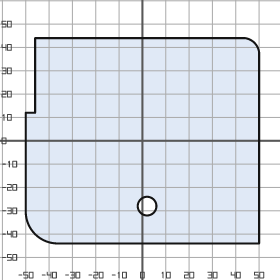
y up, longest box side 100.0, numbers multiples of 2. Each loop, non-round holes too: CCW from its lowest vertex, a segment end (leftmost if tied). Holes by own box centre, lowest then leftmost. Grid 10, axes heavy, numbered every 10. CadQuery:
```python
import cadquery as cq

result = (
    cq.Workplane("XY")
    .moveTo(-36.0, -44.0)
    .lineTo(50.0, -44.0)
    .lineTo(50.0, 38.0)
    .threePointArc((48.0, 42.0), (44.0, 44.0))
    .lineTo(-46.0, 44.0)
    .lineTo(-46.0, 12.0)
    .lineTo(-50.0, 12.0)
    .lineTo(-50.0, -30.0)
    .threePointArc((-46.0, -40.0), (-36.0, -44.0))
    .close()
    .moveTo(2.0, -28.0)
    .circle(4.0)
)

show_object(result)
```